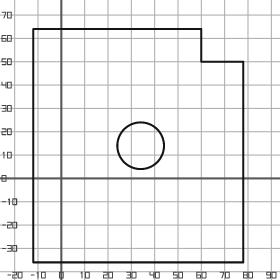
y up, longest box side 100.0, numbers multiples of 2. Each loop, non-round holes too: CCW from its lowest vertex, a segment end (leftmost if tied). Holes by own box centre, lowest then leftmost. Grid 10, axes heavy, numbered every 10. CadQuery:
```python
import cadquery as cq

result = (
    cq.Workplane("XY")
    .moveTo(-12.0, -36.0)
    .lineTo(78.0, -36.0)
    .lineTo(78.0, 50.0)
    .lineTo(60.0, 50.0)
    .lineTo(60.0, 64.0)
    .lineTo(-12.0, 64.0)
    .close()
    .moveTo(34.0, 14.0)
    .circle(10.0)
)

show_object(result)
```